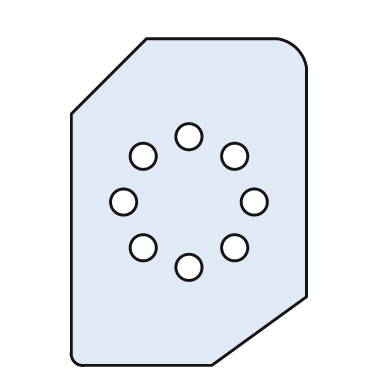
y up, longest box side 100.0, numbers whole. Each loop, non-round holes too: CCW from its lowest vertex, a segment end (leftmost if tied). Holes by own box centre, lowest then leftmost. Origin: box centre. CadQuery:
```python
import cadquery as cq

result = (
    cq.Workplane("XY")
    .moveTo(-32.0, -50.0)
    .lineTo(7.0, -50.0)
    .lineTo(36.0, -29.0)
    .lineTo(36.0, 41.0)
    .threePointArc((33.0, 47.0), (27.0, 50.0))
    .lineTo(-13.0, 50.0)
    .lineTo(-36.0, 27.0)
    .lineTo(-36.0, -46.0)
    .threePointArc((-35.0, -49.0), (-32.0, -50.0))
    .close()
    .moveTo(0.0, -20.0)
    .circle(4.0)
    .moveTo(-14.0, -14.0)
    .circle(4.0)
    .moveTo(14.0, -14.0)
    .circle(4.0)
    .moveTo(-20.0, 0.0)
    .circle(4.0)
    .moveTo(20.0, 0.0)
    .circle(4.0)
    .moveTo(-14.0, 14.0)
    .circle(4.0)
    .moveTo(14.0, 14.0)
    .circle(4.0)
    .moveTo(0.0, 20.0)
    .circle(4.0)
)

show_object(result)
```